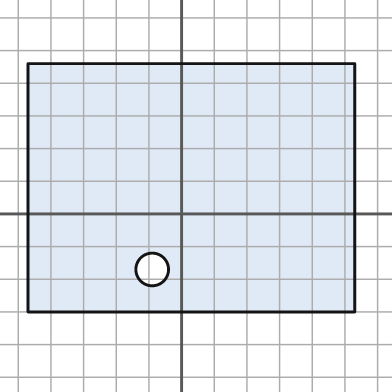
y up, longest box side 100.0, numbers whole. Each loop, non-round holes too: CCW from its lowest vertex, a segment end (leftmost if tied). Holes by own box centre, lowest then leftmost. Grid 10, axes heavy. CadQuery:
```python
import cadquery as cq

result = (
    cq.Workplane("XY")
    .moveTo(-47.0, -30.0)
    .lineTo(53.0, -30.0)
    .lineTo(53.0, 46.0)
    .lineTo(-47.0, 46.0)
    .close()
    .moveTo(-9.0, -17.0)
    .circle(5.0)
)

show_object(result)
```